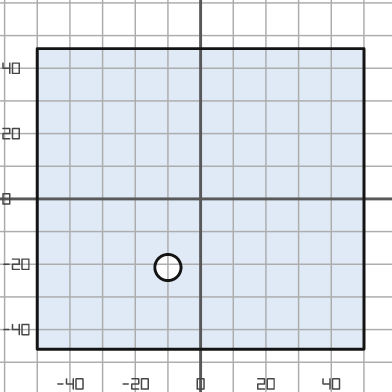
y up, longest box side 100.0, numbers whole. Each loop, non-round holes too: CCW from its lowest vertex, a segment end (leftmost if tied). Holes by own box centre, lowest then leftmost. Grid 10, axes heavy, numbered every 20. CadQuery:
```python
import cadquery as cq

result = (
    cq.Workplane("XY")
    .moveTo(-50.0, -46.0)
    .lineTo(50.0, -46.0)
    .lineTo(50.0, 46.0)
    .lineTo(-50.0, 46.0)
    .close()
    .moveTo(-10.0, -21.0)
    .circle(4.0)
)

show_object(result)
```